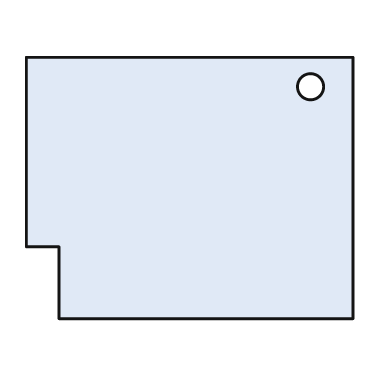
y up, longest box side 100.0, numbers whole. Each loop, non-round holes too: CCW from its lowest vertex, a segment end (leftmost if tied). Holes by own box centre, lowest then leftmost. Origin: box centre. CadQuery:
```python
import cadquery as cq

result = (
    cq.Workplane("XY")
    .moveTo(-40.0, -40.0)
    .lineTo(50.0, -40.0)
    .lineTo(50.0, 40.0)
    .lineTo(-50.0, 40.0)
    .lineTo(-50.0, -18.0)
    .lineTo(-40.0, -18.0)
    .close()
    .moveTo(37.0, 31.0)
    .circle(4.0)
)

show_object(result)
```